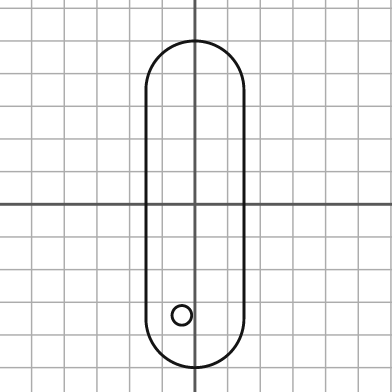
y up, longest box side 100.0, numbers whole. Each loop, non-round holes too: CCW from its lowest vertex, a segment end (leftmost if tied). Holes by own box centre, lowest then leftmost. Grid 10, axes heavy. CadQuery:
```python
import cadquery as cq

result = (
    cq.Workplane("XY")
    .moveTo(-15.0, -35.0)
    .threePointArc((0.0, -50.0), (15.0, -35.0))
    .lineTo(15.0, 35.0)
    .threePointArc((0.0, 50.0), (-15.0, 35.0))
    .close()
    .moveTo(-4.0, -34.0)
    .circle(3.0)
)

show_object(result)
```